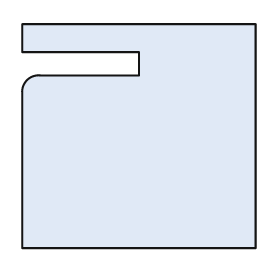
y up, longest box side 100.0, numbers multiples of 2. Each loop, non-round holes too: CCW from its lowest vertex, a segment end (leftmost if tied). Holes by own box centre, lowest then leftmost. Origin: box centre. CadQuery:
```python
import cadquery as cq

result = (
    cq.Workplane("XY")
    .moveTo(-50.0, -48.0)
    .lineTo(50.0, -48.0)
    .lineTo(50.0, 48.0)
    .lineTo(-50.0, 48.0)
    .lineTo(-50.0, 36.0)
    .lineTo(0.0, 36.0)
    .lineTo(0.0, 26.0)
    .lineTo(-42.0, 26.0)
    .threePointArc((-48.0, 24.0), (-50.0, 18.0))
    .close()
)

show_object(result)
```